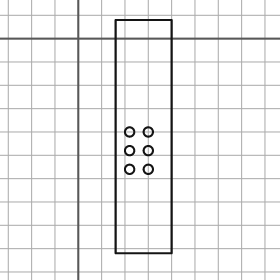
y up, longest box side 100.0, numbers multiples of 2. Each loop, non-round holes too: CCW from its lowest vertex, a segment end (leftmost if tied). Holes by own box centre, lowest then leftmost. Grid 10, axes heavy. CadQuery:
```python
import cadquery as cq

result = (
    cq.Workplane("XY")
    .moveTo(16.0, -92.0)
    .lineTo(40.0, -92.0)
    .lineTo(40.0, 8.0)
    .lineTo(16.0, 8.0)
    .close()
    .moveTo(22.0, -56.0)
    .circle(2.0)
    .moveTo(30.0, -56.0)
    .circle(2.0)
    .moveTo(22.0, -48.0)
    .circle(2.0)
    .moveTo(30.0, -48.0)
    .circle(2.0)
    .moveTo(22.0, -40.0)
    .circle(2.0)
    .moveTo(30.0, -40.0)
    .circle(2.0)
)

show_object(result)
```